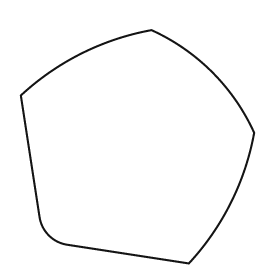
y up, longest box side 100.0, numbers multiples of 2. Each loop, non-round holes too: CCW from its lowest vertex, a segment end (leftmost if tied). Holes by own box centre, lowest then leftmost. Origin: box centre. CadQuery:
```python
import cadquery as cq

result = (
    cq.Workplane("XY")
    .moveTo(22.0, -50.0)
    .threePointArc((40.0, -24.0), (50.0, 6.0))
    .threePointArc((32.0, 32.0), (6.0, 50.0))
    .threePointArc((-24.0, 40.0), (-50.0, 22.0))
    .lineTo(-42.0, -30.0)
    .threePointArc((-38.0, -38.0), (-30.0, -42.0))
    .close()
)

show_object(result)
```